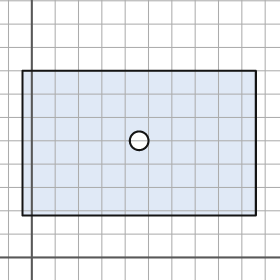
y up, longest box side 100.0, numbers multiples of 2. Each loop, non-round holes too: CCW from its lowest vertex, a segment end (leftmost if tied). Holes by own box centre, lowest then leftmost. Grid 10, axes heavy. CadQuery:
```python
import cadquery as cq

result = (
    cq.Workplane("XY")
    .moveTo(-4.0, 18.0)
    .lineTo(96.0, 18.0)
    .lineTo(96.0, 80.0)
    .lineTo(-4.0, 80.0)
    .close()
    .moveTo(46.0, 50.0)
    .circle(4.0)
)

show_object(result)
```